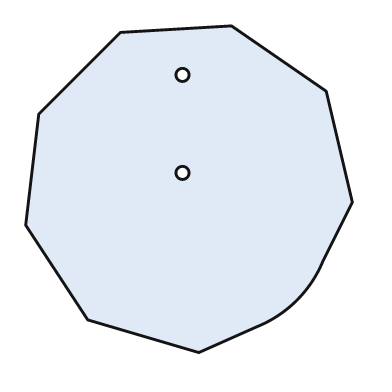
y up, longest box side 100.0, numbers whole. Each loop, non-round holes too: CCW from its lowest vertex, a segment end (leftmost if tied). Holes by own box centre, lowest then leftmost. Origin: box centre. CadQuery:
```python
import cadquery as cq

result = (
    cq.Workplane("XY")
    .moveTo(3.0, -50.0)
    .lineTo(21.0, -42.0)
    .threePointArc((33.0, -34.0), (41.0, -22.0))
    .lineTo(50.0, -4.0)
    .lineTo(42.0, 30.0)
    .lineTo(13.0, 50.0)
    .lineTo(-21.0, 48.0)
    .lineTo(-46.0, 23.0)
    .lineTo(-50.0, -11.0)
    .lineTo(-31.0, -40.0)
    .close()
    .moveTo(-2.0, 5.0)
    .circle(2.0)
    .moveTo(-2.0, 35.0)
    .circle(2.0)
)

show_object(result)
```